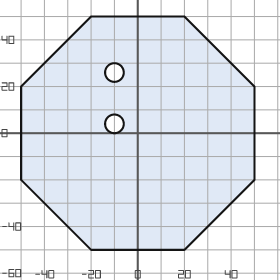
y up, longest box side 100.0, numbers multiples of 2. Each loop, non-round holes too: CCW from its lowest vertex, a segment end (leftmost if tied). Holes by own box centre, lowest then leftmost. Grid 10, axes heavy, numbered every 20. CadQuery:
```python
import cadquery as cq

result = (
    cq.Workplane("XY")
    .moveTo(-20.0, -50.0)
    .lineTo(20.0, -50.0)
    .lineTo(50.0, -20.0)
    .lineTo(50.0, 20.0)
    .lineTo(20.0, 50.0)
    .lineTo(-20.0, 50.0)
    .lineTo(-50.0, 20.0)
    .lineTo(-50.0, -20.0)
    .close()
    .moveTo(-10.0, 4.0)
    .circle(4.0)
    .moveTo(-10.0, 26.0)
    .circle(4.0)
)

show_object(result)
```